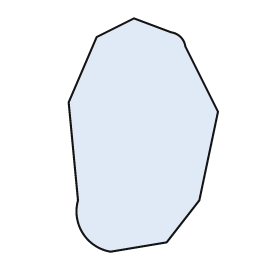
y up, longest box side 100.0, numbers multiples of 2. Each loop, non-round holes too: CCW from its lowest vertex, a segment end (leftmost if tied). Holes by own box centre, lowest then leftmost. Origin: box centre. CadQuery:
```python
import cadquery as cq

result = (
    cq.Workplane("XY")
    .moveTo(-14.0, -50.0)
    .lineTo(10.0, -46.0)
    .lineTo(24.0, -28.0)
    .lineTo(32.0, 10.0)
    .lineTo(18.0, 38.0)
    .threePointArc((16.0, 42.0), (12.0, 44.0))
    .lineTo(-4.0, 50.0)
    .lineTo(-20.0, 42.0)
    .lineTo(-32.0, 14.0)
    .lineTo(-28.0, -28.0)
    .threePointArc((-26.0, -42.0), (-14.0, -50.0))
    .close()
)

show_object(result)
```